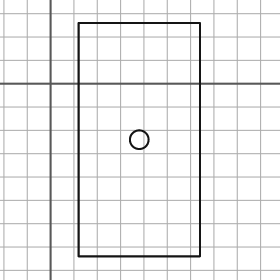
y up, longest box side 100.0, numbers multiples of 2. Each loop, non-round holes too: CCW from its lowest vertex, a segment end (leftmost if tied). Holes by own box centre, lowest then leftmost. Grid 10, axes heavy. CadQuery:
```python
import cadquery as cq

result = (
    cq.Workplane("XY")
    .moveTo(12.0, -74.0)
    .lineTo(64.0, -74.0)
    .lineTo(64.0, 26.0)
    .lineTo(12.0, 26.0)
    .close()
    .moveTo(38.0, -24.0)
    .circle(4.0)
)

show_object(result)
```